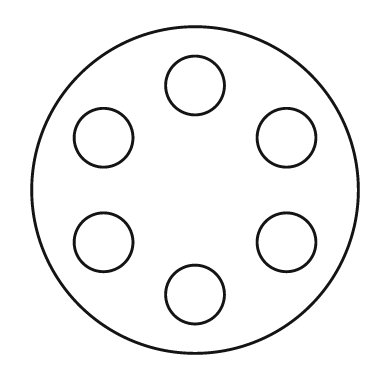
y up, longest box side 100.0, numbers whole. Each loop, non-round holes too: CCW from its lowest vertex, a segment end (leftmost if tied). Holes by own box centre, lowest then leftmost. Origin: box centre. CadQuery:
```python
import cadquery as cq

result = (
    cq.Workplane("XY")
    .moveTo(0.0, 0.0)
    .circle(50.0)
    .moveTo(0.0, -32.0)
    .circle(9.0)
    .moveTo(-28.0, -16.0)
    .circle(9.0)
    .moveTo(28.0, -16.0)
    .circle(9.0)
    .moveTo(-28.0, 16.0)
    .circle(9.0)
    .moveTo(28.0, 16.0)
    .circle(9.0)
    .moveTo(0.0, 32.0)
    .circle(9.0)
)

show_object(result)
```